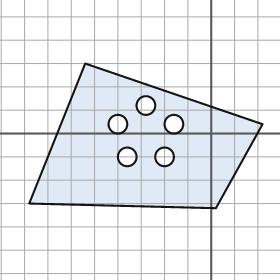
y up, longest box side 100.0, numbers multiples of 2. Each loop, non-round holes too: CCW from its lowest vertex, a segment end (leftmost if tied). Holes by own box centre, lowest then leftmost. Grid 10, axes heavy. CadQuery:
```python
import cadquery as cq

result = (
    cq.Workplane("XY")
    .moveTo(2.0, -32.0)
    .lineTo(22.0, 4.0)
    .lineTo(-54.0, 30.0)
    .lineTo(-78.0, -30.0)
    .close()
    .moveTo(-36.0, -10.0)
    .circle(4.0)
    .moveTo(-20.0, -10.0)
    .circle(4.0)
    .moveTo(-40.0, 4.0)
    .circle(4.0)
    .moveTo(-16.0, 4.0)
    .circle(4.0)
    .moveTo(-28.0, 12.0)
    .circle(4.0)
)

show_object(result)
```